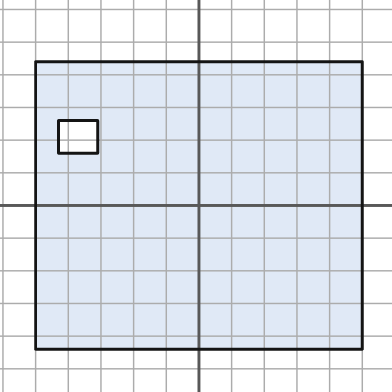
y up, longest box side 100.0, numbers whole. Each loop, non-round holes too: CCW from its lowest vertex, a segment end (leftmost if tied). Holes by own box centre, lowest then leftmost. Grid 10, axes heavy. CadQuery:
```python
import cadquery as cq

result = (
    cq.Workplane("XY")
    .moveTo(-50.0, -44.0)
    .lineTo(50.0, -44.0)
    .lineTo(50.0, 44.0)
    .lineTo(-50.0, 44.0)
    .close()
    .moveTo(-43.0, 16.0)
    .lineTo(-31.0, 16.0)
    .lineTo(-31.0, 26.0)
    .lineTo(-43.0, 26.0)
    .close()
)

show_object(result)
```